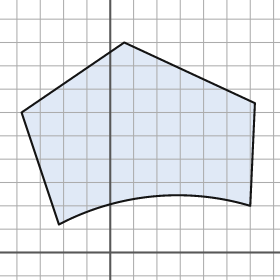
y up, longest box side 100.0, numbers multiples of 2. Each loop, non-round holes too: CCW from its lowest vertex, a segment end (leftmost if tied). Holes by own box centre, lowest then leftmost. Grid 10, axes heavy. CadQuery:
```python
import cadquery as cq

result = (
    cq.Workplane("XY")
    .moveTo(-22.0, 12.0)
    .threePointArc((18.0, 24.0), (60.0, 20.0))
    .lineTo(62.0, 64.0)
    .lineTo(6.0, 90.0)
    .lineTo(-38.0, 60.0)
    .close()
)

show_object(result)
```